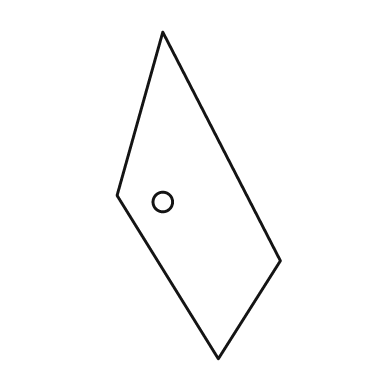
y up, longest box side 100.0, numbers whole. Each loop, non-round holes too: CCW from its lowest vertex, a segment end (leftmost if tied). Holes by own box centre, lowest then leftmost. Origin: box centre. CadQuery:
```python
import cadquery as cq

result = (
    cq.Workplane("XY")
    .moveTo(6.0, -50.0)
    .lineTo(25.0, -20.0)
    .lineTo(-11.0, 50.0)
    .lineTo(-25.0, 0.0)
    .close()
    .moveTo(-11.0, -2.0)
    .circle(3.0)
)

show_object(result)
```